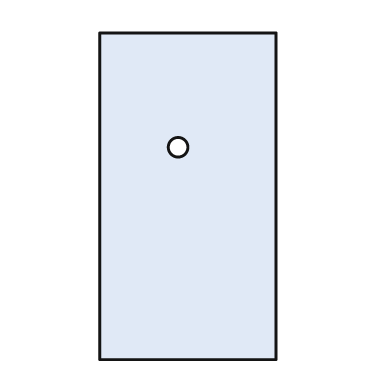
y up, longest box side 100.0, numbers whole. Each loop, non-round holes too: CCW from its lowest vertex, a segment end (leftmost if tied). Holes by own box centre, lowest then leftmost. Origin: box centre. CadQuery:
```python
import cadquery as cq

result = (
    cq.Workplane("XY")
    .moveTo(-27.0, -50.0)
    .lineTo(27.0, -50.0)
    .lineTo(27.0, 50.0)
    .lineTo(-27.0, 50.0)
    .close()
    .moveTo(-3.0, 15.0)
    .circle(3.0)
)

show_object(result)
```